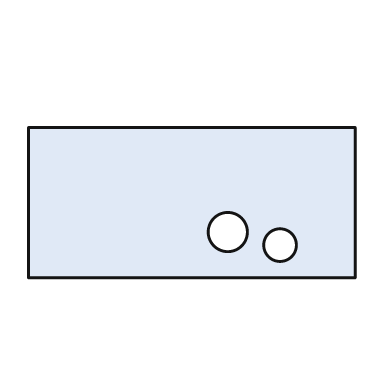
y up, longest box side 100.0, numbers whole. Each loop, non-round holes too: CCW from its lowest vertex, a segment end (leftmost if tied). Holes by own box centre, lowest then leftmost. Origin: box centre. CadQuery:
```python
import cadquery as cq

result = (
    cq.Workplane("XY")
    .moveTo(-50.0, -23.0)
    .lineTo(50.0, -23.0)
    .lineTo(50.0, 23.0)
    .lineTo(-50.0, 23.0)
    .close()
    .moveTo(27.0, -13.0)
    .circle(5.0)
    .moveTo(11.0, -9.0)
    .circle(6.0)
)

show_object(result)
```